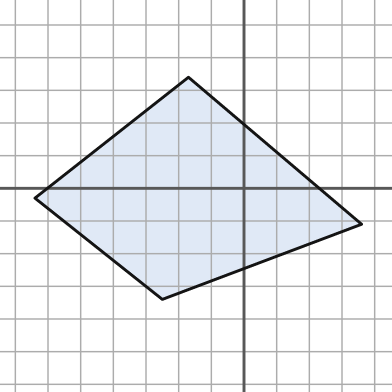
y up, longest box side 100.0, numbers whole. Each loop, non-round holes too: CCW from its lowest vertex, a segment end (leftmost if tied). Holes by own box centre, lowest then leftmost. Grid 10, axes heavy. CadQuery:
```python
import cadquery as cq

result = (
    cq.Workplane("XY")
    .moveTo(-25.0, -34.0)
    .lineTo(36.0, -11.0)
    .lineTo(-17.0, 34.0)
    .lineTo(-64.0, -3.0)
    .close()
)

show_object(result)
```